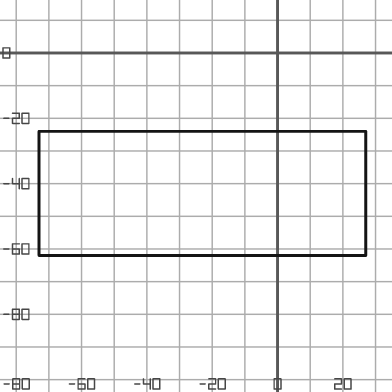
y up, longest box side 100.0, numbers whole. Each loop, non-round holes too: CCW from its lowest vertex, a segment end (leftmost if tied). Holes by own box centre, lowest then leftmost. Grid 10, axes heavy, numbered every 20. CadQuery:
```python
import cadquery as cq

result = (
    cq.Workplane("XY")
    .moveTo(-73.0, -62.0)
    .lineTo(27.0, -62.0)
    .lineTo(27.0, -24.0)
    .lineTo(-73.0, -24.0)
    .close()
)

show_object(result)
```